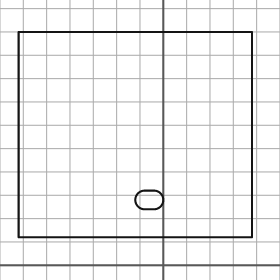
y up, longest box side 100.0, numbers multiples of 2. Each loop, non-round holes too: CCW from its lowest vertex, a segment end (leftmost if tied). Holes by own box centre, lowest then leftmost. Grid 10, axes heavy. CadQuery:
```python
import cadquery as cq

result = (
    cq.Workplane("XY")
    .moveTo(-62.0, 12.0)
    .lineTo(38.0, 12.0)
    .lineTo(38.0, 100.0)
    .lineTo(-62.0, 100.0)
    .close()
    .moveTo(-8.0, 24.0)
    .lineTo(-4.0, 24.0)
    .threePointArc((0.0, 28.0), (-4.0, 32.0))
    .lineTo(-8.0, 32.0)
    .threePointArc((-12.0, 28.0), (-8.0, 24.0))
    .close()
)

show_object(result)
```